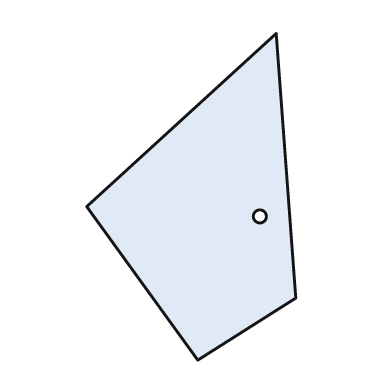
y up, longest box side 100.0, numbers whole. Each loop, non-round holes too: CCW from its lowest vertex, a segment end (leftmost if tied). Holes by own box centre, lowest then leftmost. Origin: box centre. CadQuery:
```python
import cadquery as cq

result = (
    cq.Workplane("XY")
    .moveTo(2.0, -50.0)
    .lineTo(32.0, -31.0)
    .lineTo(26.0, 50.0)
    .lineTo(-32.0, -3.0)
    .close()
    .moveTo(21.0, -6.0)
    .circle(2.0)
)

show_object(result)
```